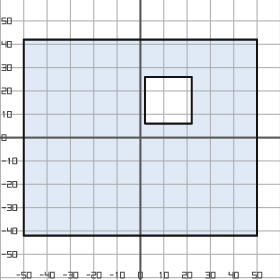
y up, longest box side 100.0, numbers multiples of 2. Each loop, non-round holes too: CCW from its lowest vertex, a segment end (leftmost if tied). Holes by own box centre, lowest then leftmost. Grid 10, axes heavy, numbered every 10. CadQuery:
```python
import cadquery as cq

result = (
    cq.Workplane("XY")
    .moveTo(-50.0, -42.0)
    .lineTo(50.0, -42.0)
    .lineTo(50.0, 42.0)
    .lineTo(-50.0, 42.0)
    .close()
    .moveTo(2.0, 6.0)
    .lineTo(22.0, 6.0)
    .lineTo(22.0, 26.0)
    .lineTo(2.0, 26.0)
    .close()
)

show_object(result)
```